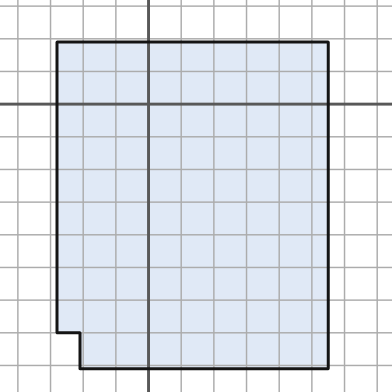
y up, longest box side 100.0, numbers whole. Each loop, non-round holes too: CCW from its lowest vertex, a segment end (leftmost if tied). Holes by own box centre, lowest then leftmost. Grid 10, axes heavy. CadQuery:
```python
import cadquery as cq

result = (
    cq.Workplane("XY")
    .moveTo(-21.0, -81.0)
    .lineTo(55.0, -81.0)
    .lineTo(55.0, 19.0)
    .lineTo(-28.0, 19.0)
    .lineTo(-28.0, -70.0)
    .lineTo(-21.0, -70.0)
    .close()
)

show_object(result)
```